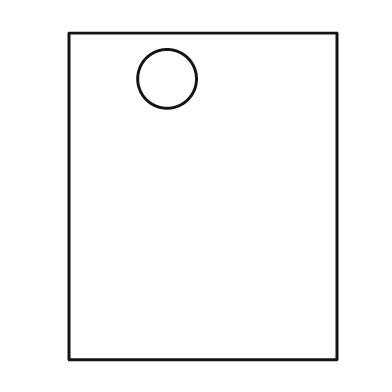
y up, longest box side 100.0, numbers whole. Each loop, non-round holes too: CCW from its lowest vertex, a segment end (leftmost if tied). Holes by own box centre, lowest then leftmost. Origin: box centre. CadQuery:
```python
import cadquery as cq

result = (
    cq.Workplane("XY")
    .moveTo(-41.0, -50.0)
    .lineTo(41.0, -50.0)
    .lineTo(41.0, 50.0)
    .lineTo(-41.0, 50.0)
    .close()
    .moveTo(-11.0, 36.0)
    .circle(9.0)
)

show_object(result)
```